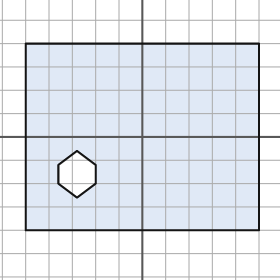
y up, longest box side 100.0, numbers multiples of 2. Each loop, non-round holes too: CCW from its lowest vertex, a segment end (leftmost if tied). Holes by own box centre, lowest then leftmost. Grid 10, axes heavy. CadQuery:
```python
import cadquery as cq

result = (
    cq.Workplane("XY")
    .moveTo(-50.0, -40.0)
    .lineTo(50.0, -40.0)
    .lineTo(50.0, 40.0)
    .lineTo(-50.0, 40.0)
    .close()
    .moveTo(-28.0, -26.0)
    .lineTo(-20.0, -20.0)
    .lineTo(-20.0, -12.0)
    .lineTo(-28.0, -6.0)
    .lineTo(-36.0, -12.0)
    .lineTo(-36.0, -20.0)
    .close()
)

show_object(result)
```